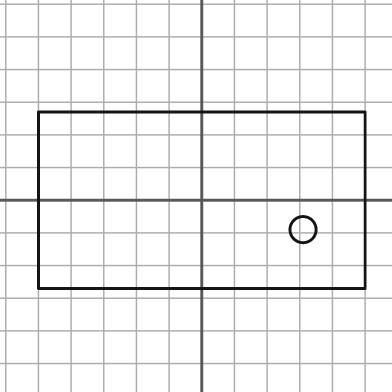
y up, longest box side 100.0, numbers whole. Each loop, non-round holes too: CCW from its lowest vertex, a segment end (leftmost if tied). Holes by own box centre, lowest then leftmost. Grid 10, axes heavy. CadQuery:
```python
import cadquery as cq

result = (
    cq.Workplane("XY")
    .moveTo(-50.0, -27.0)
    .lineTo(50.0, -27.0)
    .lineTo(50.0, 27.0)
    .lineTo(-50.0, 27.0)
    .close()
    .moveTo(31.0, -9.0)
    .circle(4.0)
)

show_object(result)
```